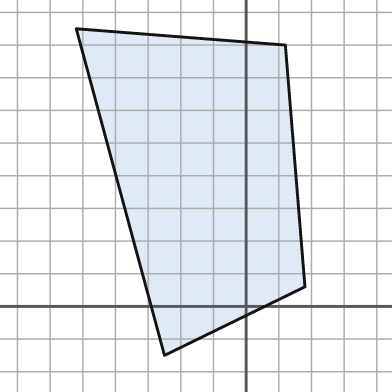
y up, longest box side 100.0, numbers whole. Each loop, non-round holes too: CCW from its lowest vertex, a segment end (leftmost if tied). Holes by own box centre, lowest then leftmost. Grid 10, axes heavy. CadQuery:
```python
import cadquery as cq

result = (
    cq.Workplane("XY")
    .moveTo(-25.0, -15.0)
    .lineTo(18.0, 6.0)
    .lineTo(12.0, 80.0)
    .lineTo(-52.0, 85.0)
    .close()
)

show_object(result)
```